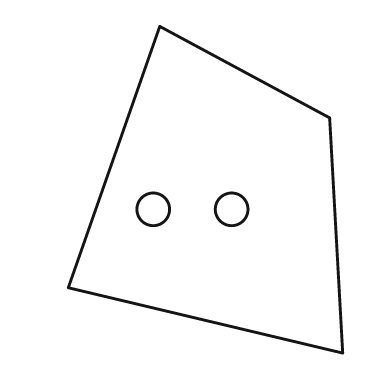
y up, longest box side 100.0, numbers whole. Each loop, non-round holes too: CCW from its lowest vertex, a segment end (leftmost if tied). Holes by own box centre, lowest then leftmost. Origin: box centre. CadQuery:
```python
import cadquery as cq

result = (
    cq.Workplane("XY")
    .moveTo(42.0, -50.0)
    .lineTo(38.0, 22.0)
    .lineTo(-14.0, 50.0)
    .lineTo(-42.0, -30.0)
    .close()
    .moveTo(-16.0, -6.0)
    .circle(5.0)
    .moveTo(8.0, -6.0)
    .circle(5.0)
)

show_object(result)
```